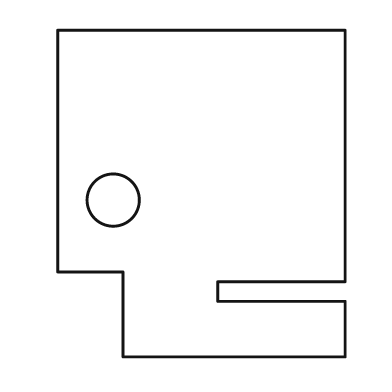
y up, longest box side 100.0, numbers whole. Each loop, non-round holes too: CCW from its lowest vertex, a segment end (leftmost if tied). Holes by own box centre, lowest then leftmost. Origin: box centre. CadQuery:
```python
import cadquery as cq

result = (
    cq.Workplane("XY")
    .moveTo(-24.0, -50.0)
    .lineTo(44.0, -50.0)
    .lineTo(44.0, -33.0)
    .lineTo(5.0, -33.0)
    .lineTo(5.0, -27.0)
    .lineTo(44.0, -27.0)
    .lineTo(44.0, 50.0)
    .lineTo(-44.0, 50.0)
    .lineTo(-44.0, -24.0)
    .lineTo(-24.0, -24.0)
    .close()
    .moveTo(-27.0, -2.0)
    .circle(8.0)
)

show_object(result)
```